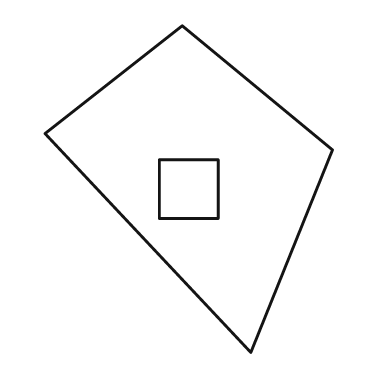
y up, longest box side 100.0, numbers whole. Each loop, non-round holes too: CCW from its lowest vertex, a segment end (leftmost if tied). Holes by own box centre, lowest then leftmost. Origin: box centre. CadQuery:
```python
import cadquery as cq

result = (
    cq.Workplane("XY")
    .moveTo(19.0, -50.0)
    .lineTo(44.0, 12.0)
    .lineTo(-2.0, 50.0)
    .lineTo(-44.0, 17.0)
    .close()
    .moveTo(-9.0, -9.0)
    .lineTo(9.0, -9.0)
    .lineTo(9.0, 9.0)
    .lineTo(-9.0, 9.0)
    .close()
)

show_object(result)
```